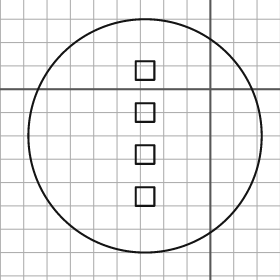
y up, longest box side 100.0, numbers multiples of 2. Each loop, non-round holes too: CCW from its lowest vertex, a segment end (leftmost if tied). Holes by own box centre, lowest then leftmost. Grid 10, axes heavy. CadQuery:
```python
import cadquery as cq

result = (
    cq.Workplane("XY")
    .moveTo(-28.0, -20.0)
    .circle(50.0)
    .moveTo(-32.0, -50.0)
    .lineTo(-24.0, -50.0)
    .lineTo(-24.0, -42.0)
    .lineTo(-32.0, -42.0)
    .close()
    .moveTo(-32.0, -32.0)
    .lineTo(-24.0, -32.0)
    .lineTo(-24.0, -24.0)
    .lineTo(-32.0, -24.0)
    .close()
    .moveTo(-32.0, -14.0)
    .lineTo(-24.0, -14.0)
    .lineTo(-24.0, -6.0)
    .lineTo(-32.0, -6.0)
    .close()
    .moveTo(-32.0, 4.0)
    .lineTo(-24.0, 4.0)
    .lineTo(-24.0, 12.0)
    .lineTo(-32.0, 12.0)
    .close()
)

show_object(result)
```